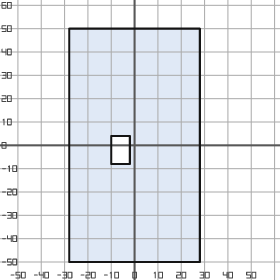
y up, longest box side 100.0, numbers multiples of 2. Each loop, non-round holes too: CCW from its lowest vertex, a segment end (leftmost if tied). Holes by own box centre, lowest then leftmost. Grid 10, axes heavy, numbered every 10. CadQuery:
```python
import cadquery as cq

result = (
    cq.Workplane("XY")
    .moveTo(-28.0, -50.0)
    .lineTo(28.0, -50.0)
    .lineTo(28.0, 50.0)
    .lineTo(-28.0, 50.0)
    .close()
    .moveTo(-10.0, -8.0)
    .lineTo(-2.0, -8.0)
    .lineTo(-2.0, 4.0)
    .lineTo(-10.0, 4.0)
    .close()
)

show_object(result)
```